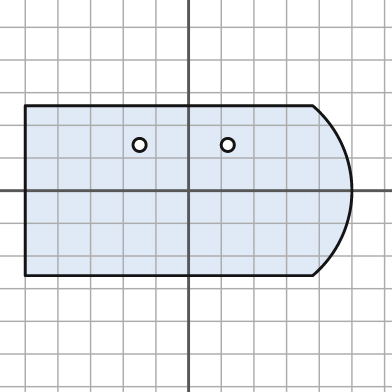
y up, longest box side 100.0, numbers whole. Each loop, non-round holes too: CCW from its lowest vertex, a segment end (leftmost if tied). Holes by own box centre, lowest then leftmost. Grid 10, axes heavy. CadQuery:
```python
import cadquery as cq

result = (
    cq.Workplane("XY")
    .moveTo(-50.0, -26.0)
    .lineTo(38.0, -26.0)
    .threePointArc((50.0, 0.0), (38.0, 26.0))
    .lineTo(-50.0, 26.0)
    .close()
    .moveTo(-15.0, 14.0)
    .circle(2.0)
    .moveTo(12.0, 14.0)
    .circle(2.0)
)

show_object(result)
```